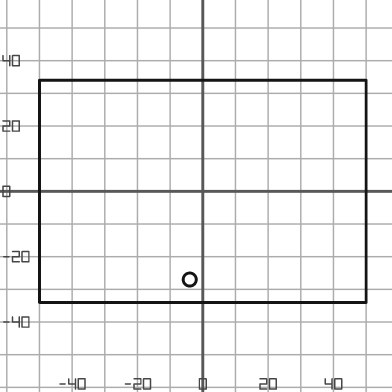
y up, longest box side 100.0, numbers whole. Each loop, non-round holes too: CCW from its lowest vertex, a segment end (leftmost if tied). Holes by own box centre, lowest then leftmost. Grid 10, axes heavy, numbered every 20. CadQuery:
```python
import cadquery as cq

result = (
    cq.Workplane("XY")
    .moveTo(-50.0, -34.0)
    .lineTo(50.0, -34.0)
    .lineTo(50.0, 34.0)
    .lineTo(-50.0, 34.0)
    .close()
    .moveTo(-4.0, -27.0)
    .circle(2.0)
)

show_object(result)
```